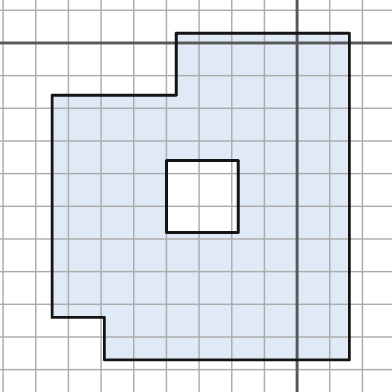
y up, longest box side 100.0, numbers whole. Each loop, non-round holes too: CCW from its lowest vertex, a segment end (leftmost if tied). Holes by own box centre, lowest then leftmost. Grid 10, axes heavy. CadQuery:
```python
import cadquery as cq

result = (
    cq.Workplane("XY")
    .moveTo(-59.0, -97.0)
    .lineTo(16.0, -97.0)
    .lineTo(16.0, 3.0)
    .lineTo(-37.0, 3.0)
    .lineTo(-37.0, -16.0)
    .lineTo(-75.0, -16.0)
    .lineTo(-75.0, -84.0)
    .lineTo(-59.0, -84.0)
    .close()
    .moveTo(-40.0, -58.0)
    .lineTo(-18.0, -58.0)
    .lineTo(-18.0, -36.0)
    .lineTo(-40.0, -36.0)
    .close()
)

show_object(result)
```